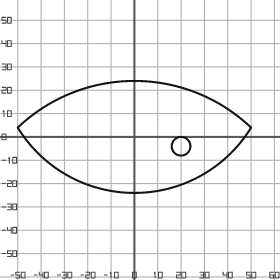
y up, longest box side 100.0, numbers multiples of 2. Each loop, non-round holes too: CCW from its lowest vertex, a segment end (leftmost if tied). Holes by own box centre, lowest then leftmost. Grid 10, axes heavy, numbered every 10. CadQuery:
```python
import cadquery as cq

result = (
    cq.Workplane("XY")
    .moveTo(-50.0, 4.0)
    .threePointArc((0.0, -24.0), (50.0, 4.0))
    .threePointArc((0.0, 24.0), (-50.0, 4.0))
    .close()
    .moveTo(20.0, -4.0)
    .circle(4.0)
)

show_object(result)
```